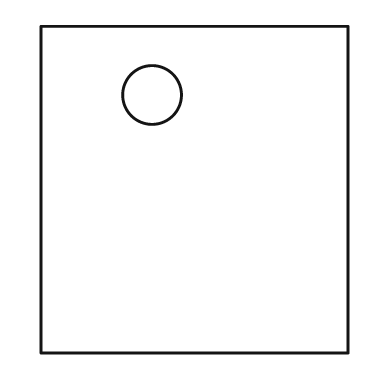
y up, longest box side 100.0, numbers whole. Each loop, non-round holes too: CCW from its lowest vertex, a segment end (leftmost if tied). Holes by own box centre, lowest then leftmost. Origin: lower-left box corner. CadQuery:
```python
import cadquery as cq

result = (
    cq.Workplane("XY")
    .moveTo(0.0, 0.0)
    .lineTo(94.0, 0.0)
    .lineTo(94.0, 100.0)
    .lineTo(0.0, 100.0)
    .close()
    .moveTo(34.0, 79.0)
    .circle(9.0)
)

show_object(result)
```